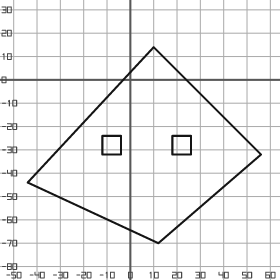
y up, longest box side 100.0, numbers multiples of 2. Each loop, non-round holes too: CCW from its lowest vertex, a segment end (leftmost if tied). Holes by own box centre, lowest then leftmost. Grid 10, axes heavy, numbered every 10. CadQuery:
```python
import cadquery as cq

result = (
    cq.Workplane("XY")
    .moveTo(12.0, -70.0)
    .lineTo(56.0, -32.0)
    .lineTo(10.0, 14.0)
    .lineTo(-44.0, -44.0)
    .close()
    .moveTo(-12.0, -32.0)
    .lineTo(-4.0, -32.0)
    .lineTo(-4.0, -24.0)
    .lineTo(-12.0, -24.0)
    .close()
    .moveTo(18.0, -32.0)
    .lineTo(26.0, -32.0)
    .lineTo(26.0, -24.0)
    .lineTo(18.0, -24.0)
    .close()
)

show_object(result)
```